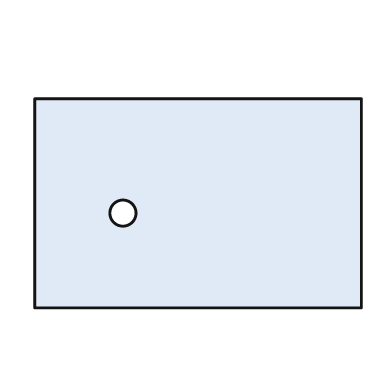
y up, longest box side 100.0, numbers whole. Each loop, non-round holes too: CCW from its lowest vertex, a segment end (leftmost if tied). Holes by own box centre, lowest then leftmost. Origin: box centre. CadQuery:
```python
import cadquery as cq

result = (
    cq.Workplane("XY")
    .moveTo(-50.0, -32.0)
    .lineTo(50.0, -32.0)
    .lineTo(50.0, 32.0)
    .lineTo(-50.0, 32.0)
    .close()
    .moveTo(-23.0, -3.0)
    .circle(4.0)
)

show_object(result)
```